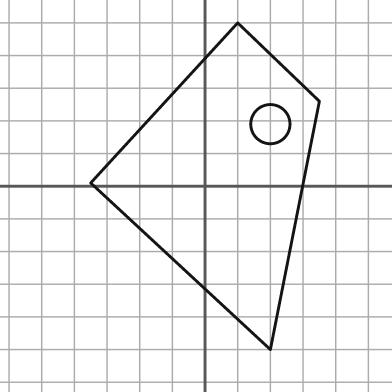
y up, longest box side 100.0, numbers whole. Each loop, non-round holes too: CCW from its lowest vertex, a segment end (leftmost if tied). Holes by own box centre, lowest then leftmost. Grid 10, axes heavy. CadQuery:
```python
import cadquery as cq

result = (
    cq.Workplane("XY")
    .moveTo(20.0, -50.0)
    .lineTo(35.0, 26.0)
    .lineTo(10.0, 50.0)
    .lineTo(-35.0, 1.0)
    .close()
    .moveTo(20.0, 19.0)
    .circle(6.0)
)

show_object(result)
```